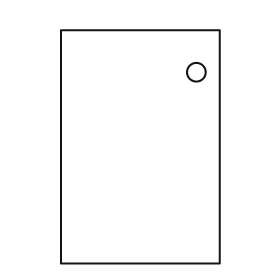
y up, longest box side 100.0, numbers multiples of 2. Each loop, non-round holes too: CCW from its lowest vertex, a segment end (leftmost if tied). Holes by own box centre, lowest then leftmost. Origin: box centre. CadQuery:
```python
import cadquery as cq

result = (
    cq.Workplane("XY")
    .moveTo(-34.0, -50.0)
    .lineTo(34.0, -50.0)
    .lineTo(34.0, 50.0)
    .lineTo(-34.0, 50.0)
    .close()
    .moveTo(24.0, 32.0)
    .circle(4.0)
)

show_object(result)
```